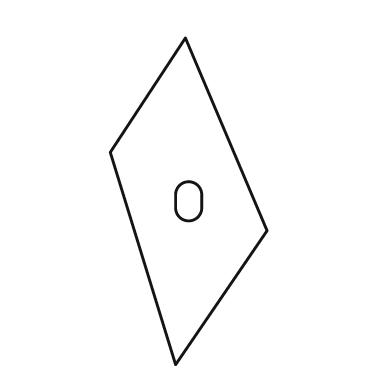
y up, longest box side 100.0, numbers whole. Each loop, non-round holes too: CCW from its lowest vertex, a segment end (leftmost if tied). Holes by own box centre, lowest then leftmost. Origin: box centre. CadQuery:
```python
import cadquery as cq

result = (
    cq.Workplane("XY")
    .moveTo(-4.0, -50.0)
    .lineTo(24.0, -9.0)
    .lineTo(-1.0, 50.0)
    .lineTo(-24.0, 15.0)
    .close()
    .moveTo(-4.0, -2.0)
    .threePointArc((0.0, -6.0), (4.0, -2.0))
    .lineTo(4.0, 2.0)
    .threePointArc((0.0, 6.0), (-4.0, 2.0))
    .close()
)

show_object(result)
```